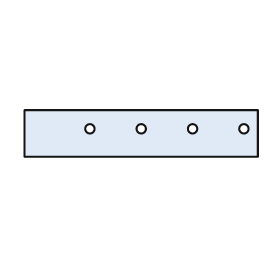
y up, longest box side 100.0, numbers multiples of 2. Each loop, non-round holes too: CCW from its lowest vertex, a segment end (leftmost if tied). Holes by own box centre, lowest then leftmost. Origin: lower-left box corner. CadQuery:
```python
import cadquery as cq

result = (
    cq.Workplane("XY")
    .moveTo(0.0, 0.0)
    .lineTo(100.0, 0.0)
    .lineTo(100.0, 20.0)
    .lineTo(0.0, 20.0)
    .close()
    .moveTo(28.0, 12.0)
    .circle(2.0)
    .moveTo(50.0, 12.0)
    .circle(2.0)
    .moveTo(72.0, 12.0)
    .circle(2.0)
    .moveTo(94.0, 12.0)
    .circle(2.0)
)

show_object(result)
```